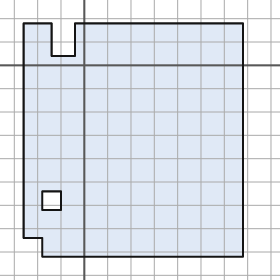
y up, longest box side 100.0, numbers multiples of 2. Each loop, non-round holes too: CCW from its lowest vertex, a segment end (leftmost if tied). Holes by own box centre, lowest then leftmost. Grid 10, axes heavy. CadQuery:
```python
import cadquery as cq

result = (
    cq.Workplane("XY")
    .moveTo(-18.0, -82.0)
    .lineTo(68.0, -82.0)
    .lineTo(68.0, 18.0)
    .lineTo(-4.0, 18.0)
    .lineTo(-4.0, 4.0)
    .lineTo(-14.0, 4.0)
    .lineTo(-14.0, 18.0)
    .lineTo(-26.0, 18.0)
    .lineTo(-26.0, -74.0)
    .lineTo(-18.0, -74.0)
    .close()
    .moveTo(-18.0, -62.0)
    .lineTo(-10.0, -62.0)
    .lineTo(-10.0, -54.0)
    .lineTo(-18.0, -54.0)
    .close()
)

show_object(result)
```